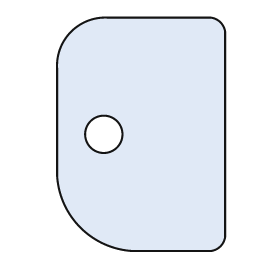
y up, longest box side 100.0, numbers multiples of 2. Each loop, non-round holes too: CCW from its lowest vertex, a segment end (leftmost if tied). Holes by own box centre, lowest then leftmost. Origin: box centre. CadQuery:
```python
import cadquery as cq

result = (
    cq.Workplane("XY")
    .moveTo(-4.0, -50.0)
    .lineTo(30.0, -50.0)
    .threePointArc((34.0, -48.0), (36.0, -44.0))
    .lineTo(36.0, 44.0)
    .threePointArc((34.0, 48.0), (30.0, 50.0))
    .lineTo(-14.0, 50.0)
    .threePointArc((-30.0, 44.0), (-36.0, 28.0))
    .lineTo(-36.0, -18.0)
    .threePointArc((-26.0, -40.0), (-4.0, -50.0))
    .close()
    .moveTo(-16.0, 0.0)
    .circle(8.0)
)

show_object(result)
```